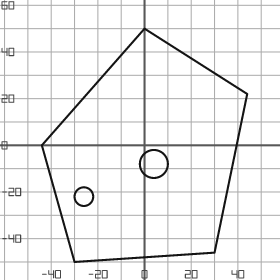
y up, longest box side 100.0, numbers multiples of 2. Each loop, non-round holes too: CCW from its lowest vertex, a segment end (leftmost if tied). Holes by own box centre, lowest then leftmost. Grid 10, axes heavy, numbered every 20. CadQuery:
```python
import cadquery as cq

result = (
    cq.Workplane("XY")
    .moveTo(-30.0, -50.0)
    .lineTo(30.0, -46.0)
    .lineTo(44.0, 22.0)
    .lineTo(0.0, 50.0)
    .lineTo(-44.0, 0.0)
    .close()
    .moveTo(-26.0, -22.0)
    .circle(4.0)
    .moveTo(4.0, -8.0)
    .circle(6.0)
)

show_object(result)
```